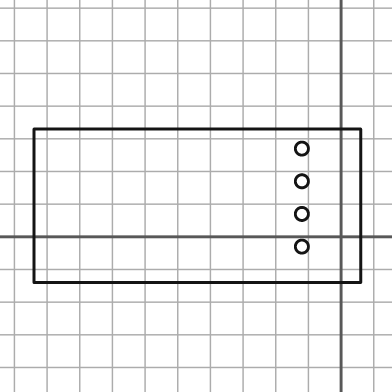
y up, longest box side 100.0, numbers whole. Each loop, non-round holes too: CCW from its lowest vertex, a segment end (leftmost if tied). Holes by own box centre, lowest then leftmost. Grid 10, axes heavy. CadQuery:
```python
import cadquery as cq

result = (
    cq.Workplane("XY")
    .moveTo(-94.0, -14.0)
    .lineTo(6.0, -14.0)
    .lineTo(6.0, 33.0)
    .lineTo(-94.0, 33.0)
    .close()
    .moveTo(-12.0, -3.0)
    .circle(2.0)
    .moveTo(-12.0, 7.0)
    .circle(2.0)
    .moveTo(-12.0, 17.0)
    .circle(2.0)
    .moveTo(-12.0, 27.0)
    .circle(2.0)
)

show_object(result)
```